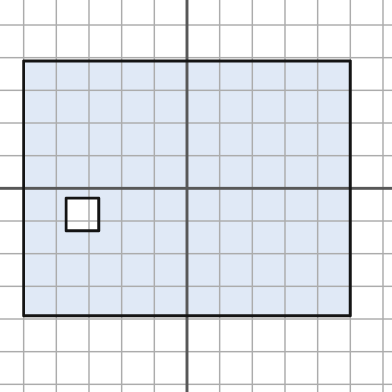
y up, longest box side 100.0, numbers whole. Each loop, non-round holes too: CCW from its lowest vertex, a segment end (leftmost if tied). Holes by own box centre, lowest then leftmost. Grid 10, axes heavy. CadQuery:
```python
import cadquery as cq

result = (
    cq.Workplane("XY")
    .moveTo(-50.0, -39.0)
    .lineTo(50.0, -39.0)
    .lineTo(50.0, 39.0)
    .lineTo(-50.0, 39.0)
    .close()
    .moveTo(-37.0, -13.0)
    .lineTo(-27.0, -13.0)
    .lineTo(-27.0, -3.0)
    .lineTo(-37.0, -3.0)
    .close()
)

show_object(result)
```